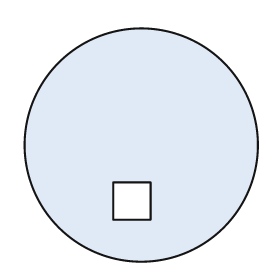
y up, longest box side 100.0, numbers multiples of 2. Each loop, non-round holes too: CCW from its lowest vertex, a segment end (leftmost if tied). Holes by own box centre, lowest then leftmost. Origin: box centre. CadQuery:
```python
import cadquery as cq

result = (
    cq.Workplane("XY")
    .moveTo(0.0, 0.0)
    .circle(50.0)
    .moveTo(-12.0, -32.0)
    .lineTo(4.0, -32.0)
    .lineTo(4.0, -16.0)
    .lineTo(-12.0, -16.0)
    .close()
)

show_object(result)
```